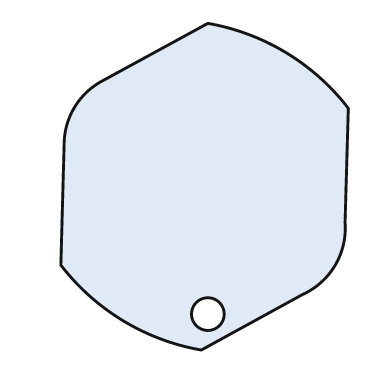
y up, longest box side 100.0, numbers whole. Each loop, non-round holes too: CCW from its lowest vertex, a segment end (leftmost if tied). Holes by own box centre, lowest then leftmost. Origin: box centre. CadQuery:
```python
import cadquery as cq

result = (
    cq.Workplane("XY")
    .moveTo(-1.0, -50.0)
    .lineTo(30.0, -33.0)
    .threePointArc((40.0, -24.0), (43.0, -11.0))
    .lineTo(44.0, 24.0)
    .threePointArc((25.0, 41.0), (1.0, 50.0))
    .lineTo(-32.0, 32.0)
    .threePointArc((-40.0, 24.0), (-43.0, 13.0))
    .lineTo(-44.0, -24.0)
    .threePointArc((-25.0, -41.0), (-1.0, -50.0))
    .close()
    .moveTo(1.0, -39.0)
    .circle(5.0)
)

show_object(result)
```